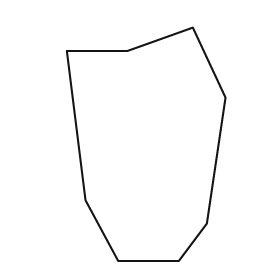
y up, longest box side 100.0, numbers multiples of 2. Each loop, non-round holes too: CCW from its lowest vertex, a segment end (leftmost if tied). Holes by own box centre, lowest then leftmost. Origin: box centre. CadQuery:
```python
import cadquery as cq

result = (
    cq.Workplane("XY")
    .moveTo(-12.0, -50.0)
    .lineTo(14.0, -50.0)
    .lineTo(26.0, -34.0)
    .lineTo(34.0, 20.0)
    .lineTo(20.0, 50.0)
    .lineTo(-8.0, 40.0)
    .lineTo(-34.0, 40.0)
    .lineTo(-26.0, -24.0)
    .close()
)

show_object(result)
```